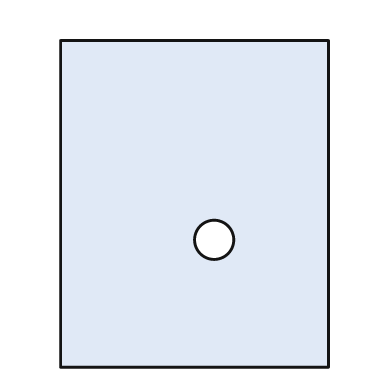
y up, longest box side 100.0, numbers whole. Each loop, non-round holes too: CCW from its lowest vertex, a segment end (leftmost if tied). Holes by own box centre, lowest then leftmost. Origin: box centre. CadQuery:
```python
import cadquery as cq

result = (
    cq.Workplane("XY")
    .moveTo(-41.0, -50.0)
    .lineTo(41.0, -50.0)
    .lineTo(41.0, 50.0)
    .lineTo(-41.0, 50.0)
    .close()
    .moveTo(6.0, -11.0)
    .circle(6.0)
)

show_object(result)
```